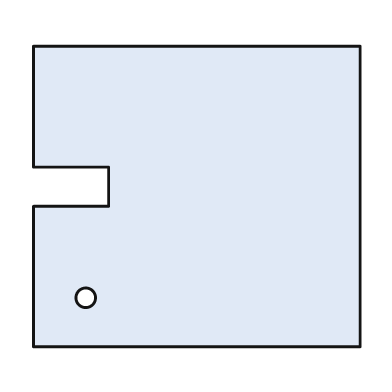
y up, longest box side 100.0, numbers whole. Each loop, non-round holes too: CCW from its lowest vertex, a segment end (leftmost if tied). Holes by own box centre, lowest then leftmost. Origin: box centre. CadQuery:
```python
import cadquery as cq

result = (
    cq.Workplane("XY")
    .moveTo(-50.0, -46.0)
    .lineTo(50.0, -46.0)
    .lineTo(50.0, 46.0)
    .lineTo(-50.0, 46.0)
    .lineTo(-50.0, 9.0)
    .lineTo(-27.0, 9.0)
    .lineTo(-27.0, -3.0)
    .lineTo(-50.0, -3.0)
    .close()
    .moveTo(-34.0, -31.0)
    .circle(3.0)
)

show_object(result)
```